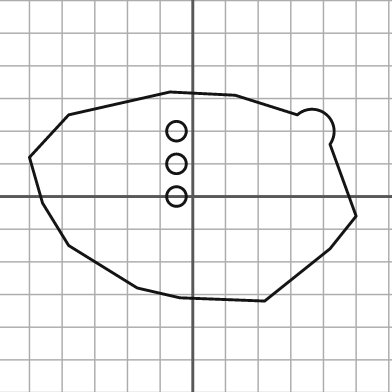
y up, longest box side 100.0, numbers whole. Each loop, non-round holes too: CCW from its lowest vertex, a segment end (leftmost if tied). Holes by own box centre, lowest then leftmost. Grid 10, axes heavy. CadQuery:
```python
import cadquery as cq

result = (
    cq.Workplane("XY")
    .moveTo(22.0, -32.0)
    .lineTo(42.0, -16.0)
    .lineTo(50.0, -6.0)
    .lineTo(42.0, 16.0)
    .threePointArc((41.0, 25.0), (32.0, 25.0))
    .lineTo(13.0, 31.0)
    .lineTo(-7.0, 32.0)
    .lineTo(-38.0, 25.0)
    .lineTo(-50.0, 12.0)
    .lineTo(-46.0, -2.0)
    .lineTo(-38.0, -15.0)
    .lineTo(-17.0, -28.0)
    .lineTo(-4.0, -31.0)
    .close()
    .moveTo(-5.0, 0.0)
    .circle(3.0)
    .moveTo(-5.0, 10.0)
    .circle(3.0)
    .moveTo(-5.0, 20.0)
    .circle(3.0)
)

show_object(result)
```